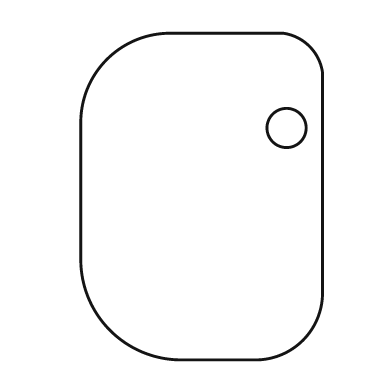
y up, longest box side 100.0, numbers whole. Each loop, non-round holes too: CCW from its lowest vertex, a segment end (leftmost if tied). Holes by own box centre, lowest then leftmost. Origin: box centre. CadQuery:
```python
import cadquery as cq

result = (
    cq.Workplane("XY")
    .moveTo(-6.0, -50.0)
    .lineTo(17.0, -50.0)
    .threePointArc((31.0, -44.0), (37.0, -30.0))
    .lineTo(37.0, 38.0)
    .threePointArc((33.0, 46.0), (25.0, 50.0))
    .lineTo(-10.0, 50.0)
    .threePointArc((-29.0, 42.0), (-37.0, 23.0))
    .lineTo(-37.0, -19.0)
    .threePointArc((-28.0, -41.0), (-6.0, -50.0))
    .close()
    .moveTo(26.0, 21.0)
    .circle(6.0)
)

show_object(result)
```